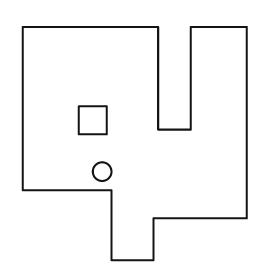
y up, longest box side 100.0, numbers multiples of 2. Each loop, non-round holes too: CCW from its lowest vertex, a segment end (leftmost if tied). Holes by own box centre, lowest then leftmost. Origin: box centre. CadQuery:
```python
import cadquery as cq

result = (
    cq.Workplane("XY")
    .moveTo(-10.0, -50.0)
    .lineTo(8.0, -50.0)
    .lineTo(8.0, -32.0)
    .lineTo(48.0, -32.0)
    .lineTo(48.0, 50.0)
    .lineTo(24.0, 50.0)
    .lineTo(24.0, 6.0)
    .lineTo(10.0, 6.0)
    .lineTo(10.0, 50.0)
    .lineTo(-48.0, 50.0)
    .lineTo(-48.0, -20.0)
    .lineTo(-10.0, -20.0)
    .close()
    .moveTo(-14.0, -12.0)
    .circle(4.0)
    .moveTo(-24.0, 4.0)
    .lineTo(-12.0, 4.0)
    .lineTo(-12.0, 16.0)
    .lineTo(-24.0, 16.0)
    .close()
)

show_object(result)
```